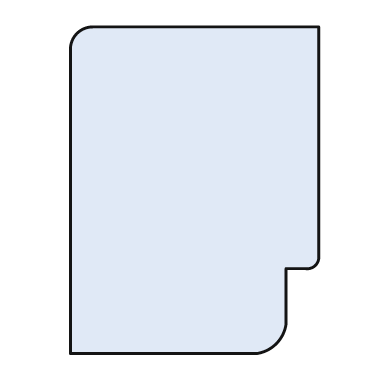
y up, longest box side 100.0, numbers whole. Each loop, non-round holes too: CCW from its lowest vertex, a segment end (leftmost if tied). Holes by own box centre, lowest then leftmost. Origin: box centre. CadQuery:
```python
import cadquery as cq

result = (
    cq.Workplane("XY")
    .moveTo(-38.0, -50.0)
    .lineTo(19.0, -50.0)
    .threePointArc((25.0, -47.0), (28.0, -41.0))
    .lineTo(28.0, -24.0)
    .lineTo(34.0, -24.0)
    .threePointArc((37.0, -23.0), (38.0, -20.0))
    .lineTo(38.0, 50.0)
    .lineTo(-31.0, 50.0)
    .threePointArc((-36.0, 48.0), (-38.0, 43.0))
    .close()
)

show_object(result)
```